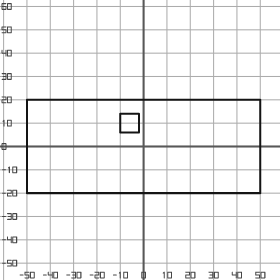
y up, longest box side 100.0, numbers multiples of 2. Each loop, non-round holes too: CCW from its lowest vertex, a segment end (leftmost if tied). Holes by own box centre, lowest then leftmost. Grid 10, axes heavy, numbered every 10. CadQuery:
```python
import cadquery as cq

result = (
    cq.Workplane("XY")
    .moveTo(-50.0, -20.0)
    .lineTo(50.0, -20.0)
    .lineTo(50.0, 20.0)
    .lineTo(-50.0, 20.0)
    .close()
    .moveTo(-10.0, 6.0)
    .lineTo(-2.0, 6.0)
    .lineTo(-2.0, 14.0)
    .lineTo(-10.0, 14.0)
    .close()
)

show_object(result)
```